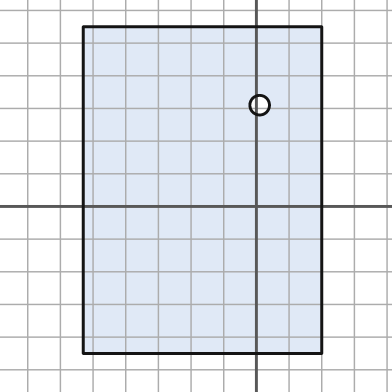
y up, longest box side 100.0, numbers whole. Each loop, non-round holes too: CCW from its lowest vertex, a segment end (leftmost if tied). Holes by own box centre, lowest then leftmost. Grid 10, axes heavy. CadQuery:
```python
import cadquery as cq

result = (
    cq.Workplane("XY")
    .moveTo(-53.0, -45.0)
    .lineTo(20.0, -45.0)
    .lineTo(20.0, 55.0)
    .lineTo(-53.0, 55.0)
    .close()
    .moveTo(1.0, 31.0)
    .circle(3.0)
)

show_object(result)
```